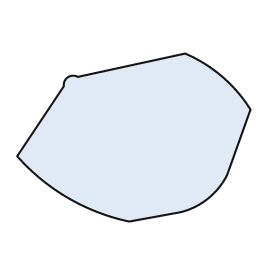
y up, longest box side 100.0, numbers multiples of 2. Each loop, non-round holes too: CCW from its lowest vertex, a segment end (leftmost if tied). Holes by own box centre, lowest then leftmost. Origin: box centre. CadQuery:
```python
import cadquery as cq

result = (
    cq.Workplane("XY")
    .moveTo(-2.0, -36.0)
    .lineTo(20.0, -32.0)
    .threePointArc((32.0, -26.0), (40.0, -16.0))
    .lineTo(50.0, 12.0)
    .threePointArc((38.0, 26.0), (22.0, 36.0))
    .lineTo(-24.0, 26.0)
    .threePointArc((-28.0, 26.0), (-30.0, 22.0))
    .lineTo(-50.0, -8.0)
    .threePointArc((-28.0, -26.0), (-2.0, -36.0))
    .close()
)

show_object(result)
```